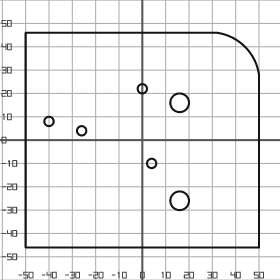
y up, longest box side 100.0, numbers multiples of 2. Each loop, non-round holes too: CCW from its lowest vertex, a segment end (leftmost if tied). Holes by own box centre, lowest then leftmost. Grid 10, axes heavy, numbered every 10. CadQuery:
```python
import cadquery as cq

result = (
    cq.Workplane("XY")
    .moveTo(-50.0, -46.0)
    .lineTo(50.0, -46.0)
    .lineTo(50.0, 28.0)
    .threePointArc((44.0, 40.0), (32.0, 46.0))
    .lineTo(-50.0, 46.0)
    .close()
    .moveTo(16.0, -26.0)
    .circle(4.0)
    .moveTo(4.0, -10.0)
    .circle(2.0)
    .moveTo(-26.0, 4.0)
    .circle(2.0)
    .moveTo(-40.0, 8.0)
    .circle(2.0)
    .moveTo(16.0, 16.0)
    .circle(4.0)
    .moveTo(0.0, 22.0)
    .circle(2.0)
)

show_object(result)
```